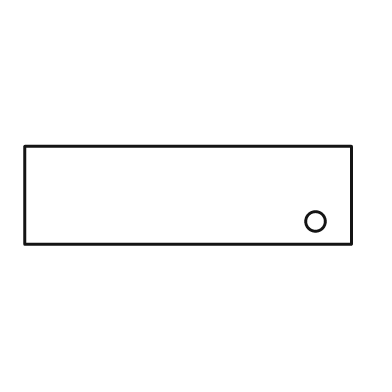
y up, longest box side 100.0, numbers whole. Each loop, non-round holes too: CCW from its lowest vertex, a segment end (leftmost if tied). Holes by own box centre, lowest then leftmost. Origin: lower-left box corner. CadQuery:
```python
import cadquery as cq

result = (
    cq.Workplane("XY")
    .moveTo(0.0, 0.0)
    .lineTo(100.0, 0.0)
    .lineTo(100.0, 30.0)
    .lineTo(0.0, 30.0)
    .close()
    .moveTo(89.0, 7.0)
    .circle(3.0)
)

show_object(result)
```